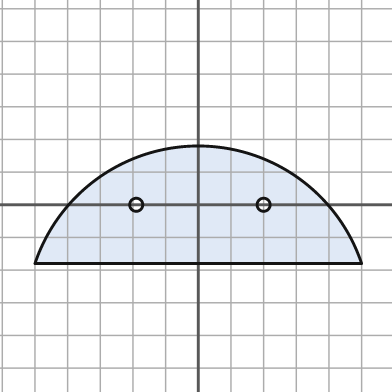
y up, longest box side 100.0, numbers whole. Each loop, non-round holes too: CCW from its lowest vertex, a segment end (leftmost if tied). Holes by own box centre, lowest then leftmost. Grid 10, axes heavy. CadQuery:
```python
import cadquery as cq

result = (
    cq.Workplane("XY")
    .moveTo(-50.0, -18.0)
    .lineTo(50.0, -18.0)
    .threePointArc((0.0, 18.0), (-50.0, -18.0))
    .close()
    .moveTo(-19.0, 0.0)
    .circle(2.0)
    .moveTo(20.0, 0.0)
    .circle(2.0)
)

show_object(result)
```